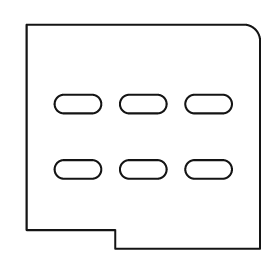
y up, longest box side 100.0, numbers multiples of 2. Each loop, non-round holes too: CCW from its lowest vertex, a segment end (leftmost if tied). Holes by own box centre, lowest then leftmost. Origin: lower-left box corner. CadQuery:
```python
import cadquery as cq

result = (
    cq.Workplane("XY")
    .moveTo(38.0, 0.0)
    .lineTo(100.0, 0.0)
    .lineTo(100.0, 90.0)
    .threePointArc((98.0, 94.0), (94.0, 96.0))
    .lineTo(0.0, 96.0)
    .lineTo(0.0, 8.0)
    .lineTo(38.0, 8.0)
    .close()
    .moveTo(16.0, 30.0)
    .lineTo(28.0, 30.0)
    .threePointArc((32.0, 34.0), (28.0, 38.0))
    .lineTo(16.0, 38.0)
    .threePointArc((12.0, 34.0), (16.0, 30.0))
    .close()
    .moveTo(44.0, 30.0)
    .lineTo(56.0, 30.0)
    .threePointArc((60.0, 34.0), (56.0, 38.0))
    .lineTo(44.0, 38.0)
    .threePointArc((40.0, 34.0), (44.0, 30.0))
    .close()
    .moveTo(72.0, 30.0)
    .lineTo(84.0, 30.0)
    .threePointArc((88.0, 34.0), (84.0, 38.0))
    .lineTo(72.0, 38.0)
    .threePointArc((68.0, 34.0), (72.0, 30.0))
    .close()
    .moveTo(16.0, 58.0)
    .lineTo(28.0, 58.0)
    .threePointArc((32.0, 62.0), (28.0, 66.0))
    .lineTo(16.0, 66.0)
    .threePointArc((12.0, 62.0), (16.0, 58.0))
    .close()
    .moveTo(44.0, 58.0)
    .lineTo(56.0, 58.0)
    .threePointArc((60.0, 62.0), (56.0, 66.0))
    .lineTo(44.0, 66.0)
    .threePointArc((40.0, 62.0), (44.0, 58.0))
    .close()
    .moveTo(72.0, 58.0)
    .lineTo(84.0, 58.0)
    .threePointArc((88.0, 62.0), (84.0, 66.0))
    .lineTo(72.0, 66.0)
    .threePointArc((68.0, 62.0), (72.0, 58.0))
    .close()
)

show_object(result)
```